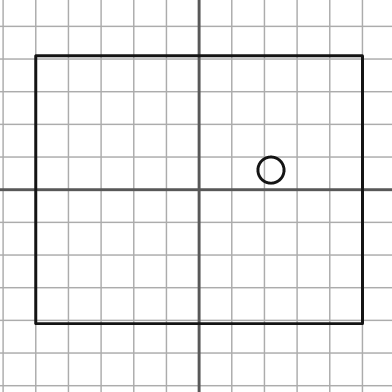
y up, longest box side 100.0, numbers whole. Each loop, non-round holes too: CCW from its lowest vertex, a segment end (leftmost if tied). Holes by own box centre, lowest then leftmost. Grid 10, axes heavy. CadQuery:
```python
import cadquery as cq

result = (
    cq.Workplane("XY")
    .moveTo(-50.0, -41.0)
    .lineTo(50.0, -41.0)
    .lineTo(50.0, 41.0)
    .lineTo(-50.0, 41.0)
    .close()
    .moveTo(22.0, 6.0)
    .circle(4.0)
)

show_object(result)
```